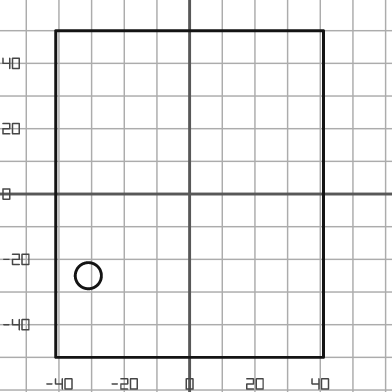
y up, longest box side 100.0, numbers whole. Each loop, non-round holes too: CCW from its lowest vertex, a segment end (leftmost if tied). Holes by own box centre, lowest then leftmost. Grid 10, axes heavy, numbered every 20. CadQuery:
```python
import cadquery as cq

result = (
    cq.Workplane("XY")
    .moveTo(-41.0, -50.0)
    .lineTo(41.0, -50.0)
    .lineTo(41.0, 50.0)
    .lineTo(-41.0, 50.0)
    .close()
    .moveTo(-31.0, -25.0)
    .circle(4.0)
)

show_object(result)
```